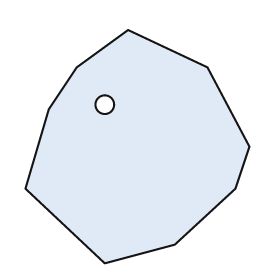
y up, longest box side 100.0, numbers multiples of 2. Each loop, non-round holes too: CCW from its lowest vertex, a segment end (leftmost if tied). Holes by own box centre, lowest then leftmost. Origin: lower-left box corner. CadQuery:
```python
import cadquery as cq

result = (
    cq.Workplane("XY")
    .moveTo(34.0, 0.0)
    .lineTo(64.0, 8.0)
    .lineTo(90.0, 32.0)
    .lineTo(96.0, 50.0)
    .lineTo(78.0, 84.0)
    .lineTo(44.0, 100.0)
    .lineTo(22.0, 84.0)
    .lineTo(10.0, 66.0)
    .lineTo(0.0, 32.0)
    .close()
    .moveTo(34.0, 68.0)
    .circle(4.0)
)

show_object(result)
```